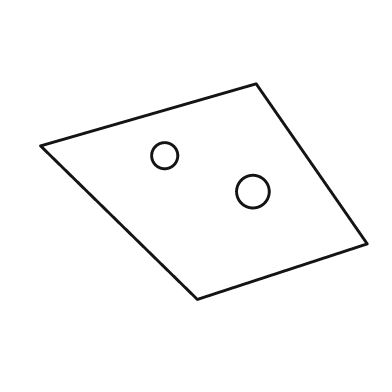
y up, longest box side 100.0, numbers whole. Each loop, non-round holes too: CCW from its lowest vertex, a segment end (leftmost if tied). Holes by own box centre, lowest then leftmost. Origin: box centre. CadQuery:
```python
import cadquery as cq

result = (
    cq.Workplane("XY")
    .moveTo(-2.0, -33.0)
    .lineTo(50.0, -16.0)
    .lineTo(16.0, 33.0)
    .lineTo(-50.0, 14.0)
    .close()
    .moveTo(15.0, 0.0)
    .circle(5.0)
    .moveTo(-12.0, 11.0)
    .circle(4.0)
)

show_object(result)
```